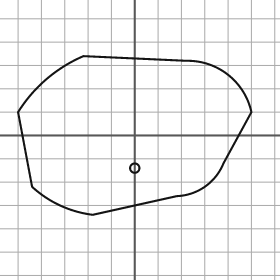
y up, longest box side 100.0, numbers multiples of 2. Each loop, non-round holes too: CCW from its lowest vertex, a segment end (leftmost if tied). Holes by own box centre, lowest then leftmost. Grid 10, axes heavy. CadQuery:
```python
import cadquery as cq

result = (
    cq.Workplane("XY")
    .moveTo(-18.0, -34.0)
    .lineTo(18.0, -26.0)
    .threePointArc((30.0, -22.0), (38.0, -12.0))
    .lineTo(50.0, 10.0)
    .threePointArc((40.0, 26.0), (22.0, 32.0))
    .lineTo(-22.0, 34.0)
    .threePointArc((-38.0, 24.0), (-50.0, 10.0))
    .lineTo(-44.0, -22.0)
    .threePointArc((-32.0, -30.0), (-18.0, -34.0))
    .close()
    .moveTo(0.0, -14.0)
    .circle(2.0)
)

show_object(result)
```